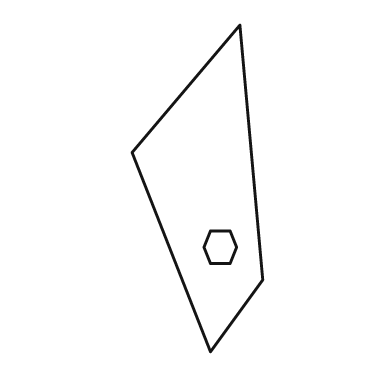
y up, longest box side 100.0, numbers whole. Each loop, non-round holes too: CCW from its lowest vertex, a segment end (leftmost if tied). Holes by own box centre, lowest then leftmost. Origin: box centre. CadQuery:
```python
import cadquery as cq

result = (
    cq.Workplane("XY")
    .moveTo(4.0, -50.0)
    .lineTo(20.0, -28.0)
    .lineTo(13.0, 50.0)
    .lineTo(-20.0, 11.0)
    .close()
    .moveTo(4.0, -23.0)
    .lineTo(10.0, -23.0)
    .lineTo(12.0, -18.0)
    .lineTo(10.0, -13.0)
    .lineTo(4.0, -13.0)
    .lineTo(2.0, -18.0)
    .close()
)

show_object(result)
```